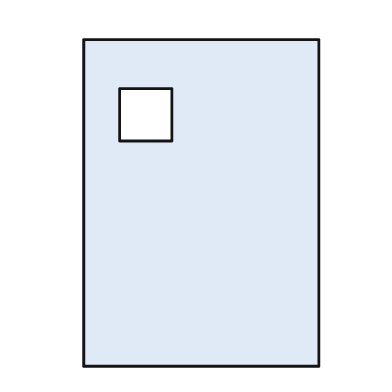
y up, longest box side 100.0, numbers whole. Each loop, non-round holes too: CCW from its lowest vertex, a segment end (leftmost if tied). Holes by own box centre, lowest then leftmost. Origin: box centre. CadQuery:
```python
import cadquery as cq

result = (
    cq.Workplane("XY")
    .moveTo(-36.0, -50.0)
    .lineTo(36.0, -50.0)
    .lineTo(36.0, 50.0)
    .lineTo(-36.0, 50.0)
    .close()
    .moveTo(-25.0, 19.0)
    .lineTo(-9.0, 19.0)
    .lineTo(-9.0, 35.0)
    .lineTo(-25.0, 35.0)
    .close()
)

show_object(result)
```